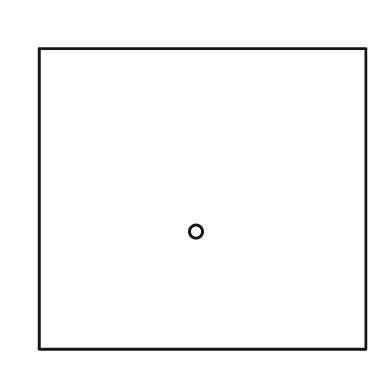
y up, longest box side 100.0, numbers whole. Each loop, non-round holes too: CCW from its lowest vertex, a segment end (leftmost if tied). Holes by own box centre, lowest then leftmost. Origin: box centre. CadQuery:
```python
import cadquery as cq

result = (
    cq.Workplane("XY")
    .moveTo(-50.0, -46.0)
    .lineTo(50.0, -46.0)
    .lineTo(50.0, 46.0)
    .lineTo(-50.0, 46.0)
    .close()
    .moveTo(-2.0, -10.0)
    .circle(2.0)
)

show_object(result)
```